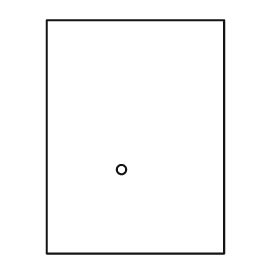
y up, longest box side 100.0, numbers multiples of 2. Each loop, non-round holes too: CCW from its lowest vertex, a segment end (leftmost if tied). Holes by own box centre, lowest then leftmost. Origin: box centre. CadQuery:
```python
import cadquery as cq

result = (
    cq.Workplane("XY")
    .moveTo(-38.0, -50.0)
    .lineTo(38.0, -50.0)
    .lineTo(38.0, 50.0)
    .lineTo(-38.0, 50.0)
    .close()
    .moveTo(-6.0, -14.0)
    .circle(2.0)
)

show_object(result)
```